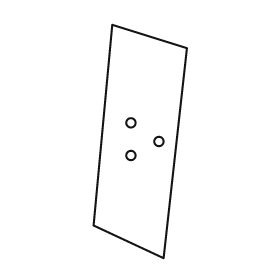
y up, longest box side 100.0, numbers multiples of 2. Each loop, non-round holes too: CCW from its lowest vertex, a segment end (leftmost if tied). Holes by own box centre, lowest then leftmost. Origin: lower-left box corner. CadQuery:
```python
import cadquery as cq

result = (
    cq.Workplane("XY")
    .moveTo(30.0, 0.0)
    .lineTo(40.0, 90.0)
    .lineTo(8.0, 100.0)
    .lineTo(0.0, 14.0)
    .close()
    .moveTo(16.0, 44.0)
    .circle(2.0)
    .moveTo(28.0, 50.0)
    .circle(2.0)
    .moveTo(16.0, 58.0)
    .circle(2.0)
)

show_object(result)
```